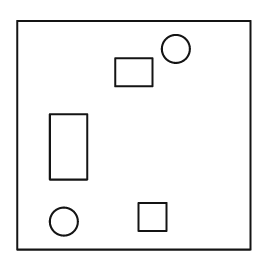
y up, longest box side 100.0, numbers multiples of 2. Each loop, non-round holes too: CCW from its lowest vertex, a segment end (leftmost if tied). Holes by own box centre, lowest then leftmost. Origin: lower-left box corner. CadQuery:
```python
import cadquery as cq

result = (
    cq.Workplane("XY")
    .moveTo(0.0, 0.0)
    .lineTo(100.0, 0.0)
    .lineTo(100.0, 98.0)
    .lineTo(0.0, 98.0)
    .close()
    .moveTo(20.0, 12.0)
    .circle(6.0)
    .moveTo(52.0, 8.0)
    .lineTo(64.0, 8.0)
    .lineTo(64.0, 20.0)
    .lineTo(52.0, 20.0)
    .close()
    .moveTo(14.0, 30.0)
    .lineTo(30.0, 30.0)
    .lineTo(30.0, 58.0)
    .lineTo(14.0, 58.0)
    .close()
    .moveTo(42.0, 70.0)
    .lineTo(58.0, 70.0)
    .lineTo(58.0, 82.0)
    .lineTo(42.0, 82.0)
    .close()
    .moveTo(68.0, 86.0)
    .circle(6.0)
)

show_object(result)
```